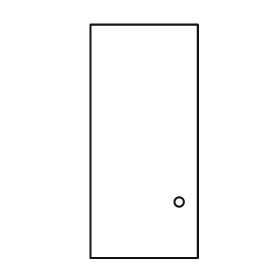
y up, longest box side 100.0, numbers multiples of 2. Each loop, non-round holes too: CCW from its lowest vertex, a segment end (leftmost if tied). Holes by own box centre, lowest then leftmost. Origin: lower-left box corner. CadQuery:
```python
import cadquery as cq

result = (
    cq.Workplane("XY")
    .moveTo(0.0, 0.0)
    .lineTo(46.0, 0.0)
    .lineTo(46.0, 100.0)
    .lineTo(0.0, 100.0)
    .close()
    .moveTo(38.0, 24.0)
    .circle(2.0)
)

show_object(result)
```